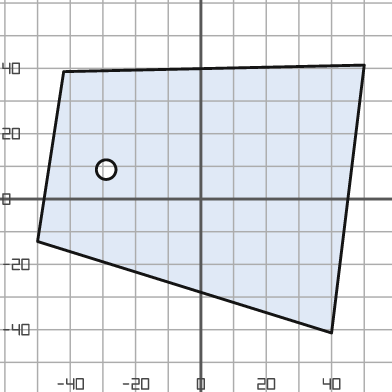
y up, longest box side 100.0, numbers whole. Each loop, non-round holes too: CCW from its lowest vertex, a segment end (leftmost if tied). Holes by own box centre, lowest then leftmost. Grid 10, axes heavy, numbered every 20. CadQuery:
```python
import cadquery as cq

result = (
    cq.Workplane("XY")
    .moveTo(40.0, -41.0)
    .lineTo(50.0, 41.0)
    .lineTo(-42.0, 39.0)
    .lineTo(-50.0, -13.0)
    .close()
    .moveTo(-29.0, 9.0)
    .circle(3.0)
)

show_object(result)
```